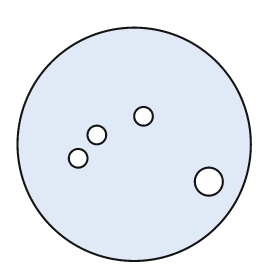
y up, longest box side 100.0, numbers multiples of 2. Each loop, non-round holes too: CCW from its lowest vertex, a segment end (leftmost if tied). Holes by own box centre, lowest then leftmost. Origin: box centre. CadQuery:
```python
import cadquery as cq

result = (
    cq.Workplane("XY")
    .moveTo(0.0, 0.0)
    .circle(50.0)
    .moveTo(32.0, -16.0)
    .circle(6.0)
    .moveTo(-24.0, -6.0)
    .circle(4.0)
    .moveTo(-16.0, 4.0)
    .circle(4.0)
    .moveTo(4.0, 12.0)
    .circle(4.0)
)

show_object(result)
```